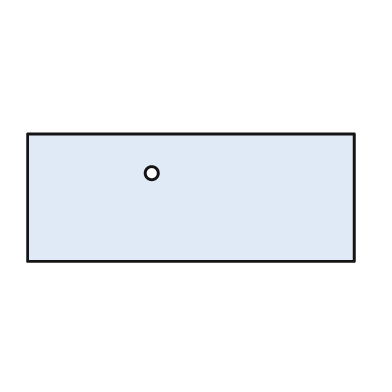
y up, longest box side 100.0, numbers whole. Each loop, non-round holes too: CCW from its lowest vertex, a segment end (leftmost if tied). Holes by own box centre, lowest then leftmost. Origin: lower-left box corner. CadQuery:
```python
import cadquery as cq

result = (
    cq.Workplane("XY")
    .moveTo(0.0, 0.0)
    .lineTo(100.0, 0.0)
    .lineTo(100.0, 39.0)
    .lineTo(0.0, 39.0)
    .close()
    .moveTo(38.0, 27.0)
    .circle(2.0)
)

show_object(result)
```